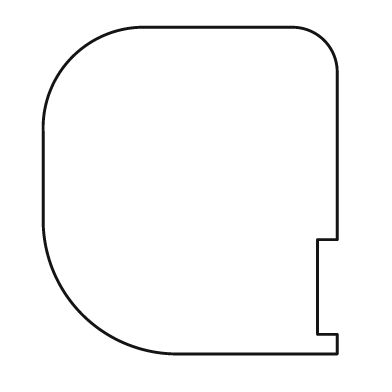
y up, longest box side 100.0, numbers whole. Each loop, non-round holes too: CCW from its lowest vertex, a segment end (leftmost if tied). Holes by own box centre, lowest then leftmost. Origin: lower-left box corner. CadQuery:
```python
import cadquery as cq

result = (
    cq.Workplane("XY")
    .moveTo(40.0, 0.0)
    .lineTo(90.0, 0.0)
    .lineTo(90.0, 6.0)
    .lineTo(84.0, 6.0)
    .lineTo(84.0, 35.0)
    .lineTo(90.0, 35.0)
    .lineTo(90.0, 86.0)
    .threePointArc((86.0, 96.0), (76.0, 100.0))
    .lineTo(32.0, 100.0)
    .threePointArc((9.0, 91.0), (0.0, 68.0))
    .lineTo(0.0, 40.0)
    .threePointArc((12.0, 12.0), (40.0, 0.0))
    .close()
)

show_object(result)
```